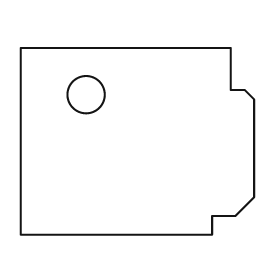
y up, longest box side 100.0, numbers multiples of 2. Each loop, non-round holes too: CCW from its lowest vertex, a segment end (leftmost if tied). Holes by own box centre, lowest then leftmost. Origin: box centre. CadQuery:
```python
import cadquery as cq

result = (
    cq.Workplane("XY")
    .moveTo(-50.0, -40.0)
    .lineTo(32.0, -40.0)
    .lineTo(32.0, -32.0)
    .lineTo(42.0, -32.0)
    .lineTo(50.0, -24.0)
    .lineTo(50.0, 18.0)
    .lineTo(46.0, 22.0)
    .lineTo(40.0, 22.0)
    .lineTo(40.0, 40.0)
    .lineTo(-50.0, 40.0)
    .close()
    .moveTo(-22.0, 20.0)
    .circle(8.0)
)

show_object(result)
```